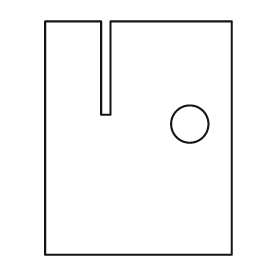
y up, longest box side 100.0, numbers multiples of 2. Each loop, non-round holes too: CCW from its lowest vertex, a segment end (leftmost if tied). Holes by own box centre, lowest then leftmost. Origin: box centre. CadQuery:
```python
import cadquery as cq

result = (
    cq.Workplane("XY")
    .moveTo(-40.0, -50.0)
    .lineTo(40.0, -50.0)
    .lineTo(40.0, 50.0)
    .lineTo(-12.0, 50.0)
    .lineTo(-12.0, 10.0)
    .lineTo(-16.0, 10.0)
    .lineTo(-16.0, 50.0)
    .lineTo(-40.0, 50.0)
    .close()
    .moveTo(22.0, 6.0)
    .circle(8.0)
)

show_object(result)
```